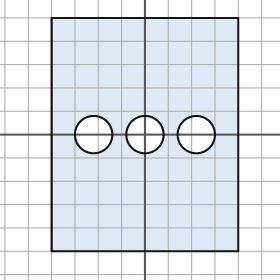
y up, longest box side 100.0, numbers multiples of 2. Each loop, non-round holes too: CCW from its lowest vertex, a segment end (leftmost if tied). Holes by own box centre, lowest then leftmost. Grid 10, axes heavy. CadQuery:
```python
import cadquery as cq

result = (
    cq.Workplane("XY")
    .moveTo(-40.0, -50.0)
    .lineTo(40.0, -50.0)
    .lineTo(40.0, 50.0)
    .lineTo(-40.0, 50.0)
    .close()
    .moveTo(-22.0, 0.0)
    .circle(8.0)
    .moveTo(0.0, 0.0)
    .circle(8.0)
    .moveTo(22.0, 0.0)
    .circle(8.0)
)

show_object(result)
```